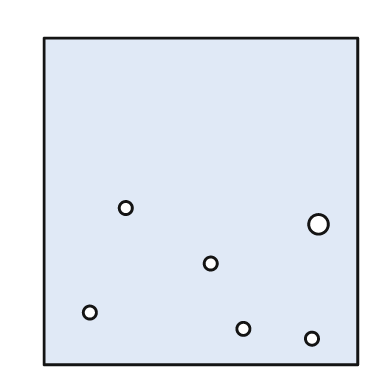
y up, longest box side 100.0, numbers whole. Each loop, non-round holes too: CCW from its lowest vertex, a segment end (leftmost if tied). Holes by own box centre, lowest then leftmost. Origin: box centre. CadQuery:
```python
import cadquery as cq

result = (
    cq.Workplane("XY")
    .moveTo(-48.0, -50.0)
    .lineTo(48.0, -50.0)
    .lineTo(48.0, 50.0)
    .lineTo(-48.0, 50.0)
    .close()
    .moveTo(34.0, -42.0)
    .circle(2.0)
    .moveTo(13.0, -39.0)
    .circle(2.0)
    .moveTo(-34.0, -34.0)
    .circle(2.0)
    .moveTo(3.0, -19.0)
    .circle(2.0)
    .moveTo(36.0, -7.0)
    .circle(3.0)
    .moveTo(-23.0, -2.0)
    .circle(2.0)
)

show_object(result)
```